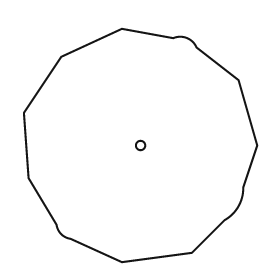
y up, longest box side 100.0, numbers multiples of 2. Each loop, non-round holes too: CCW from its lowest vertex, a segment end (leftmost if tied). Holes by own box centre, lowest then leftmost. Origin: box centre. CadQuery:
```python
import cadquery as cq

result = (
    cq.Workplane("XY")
    .moveTo(-8.0, -50.0)
    .lineTo(22.0, -46.0)
    .lineTo(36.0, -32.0)
    .threePointArc((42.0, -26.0), (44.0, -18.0))
    .lineTo(50.0, 0.0)
    .lineTo(42.0, 28.0)
    .lineTo(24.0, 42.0)
    .threePointArc((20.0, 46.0), (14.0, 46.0))
    .lineTo(-8.0, 50.0)
    .lineTo(-34.0, 38.0)
    .lineTo(-50.0, 14.0)
    .lineTo(-48.0, -14.0)
    .lineTo(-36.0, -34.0)
    .threePointArc((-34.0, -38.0), (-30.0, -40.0))
    .close()
    .moveTo(0.0, 0.0)
    .circle(2.0)
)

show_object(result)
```